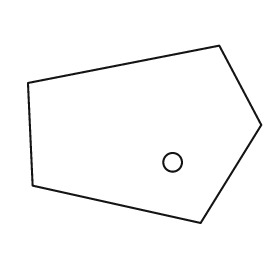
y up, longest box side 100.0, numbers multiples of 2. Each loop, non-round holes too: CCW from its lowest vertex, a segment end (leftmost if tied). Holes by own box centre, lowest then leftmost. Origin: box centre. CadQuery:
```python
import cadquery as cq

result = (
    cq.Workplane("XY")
    .moveTo(24.0, -38.0)
    .lineTo(50.0, 4.0)
    .lineTo(32.0, 38.0)
    .lineTo(-50.0, 22.0)
    .lineTo(-48.0, -22.0)
    .close()
    .moveTo(12.0, -12.0)
    .circle(4.0)
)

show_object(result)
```